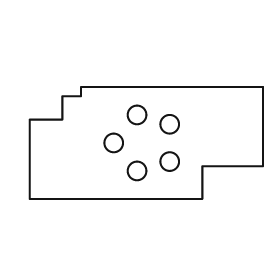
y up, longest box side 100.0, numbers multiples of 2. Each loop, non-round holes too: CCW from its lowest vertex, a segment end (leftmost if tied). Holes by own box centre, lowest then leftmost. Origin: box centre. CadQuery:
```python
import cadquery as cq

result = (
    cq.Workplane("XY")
    .moveTo(-50.0, -24.0)
    .lineTo(24.0, -24.0)
    .lineTo(24.0, -10.0)
    .lineTo(50.0, -10.0)
    .lineTo(50.0, 24.0)
    .lineTo(-28.0, 24.0)
    .lineTo(-28.0, 20.0)
    .lineTo(-36.0, 20.0)
    .lineTo(-36.0, 10.0)
    .lineTo(-50.0, 10.0)
    .close()
    .moveTo(-4.0, -12.0)
    .circle(4.0)
    .moveTo(10.0, -8.0)
    .circle(4.0)
    .moveTo(-14.0, 0.0)
    .circle(4.0)
    .moveTo(10.0, 8.0)
    .circle(4.0)
    .moveTo(-4.0, 12.0)
    .circle(4.0)
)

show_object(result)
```